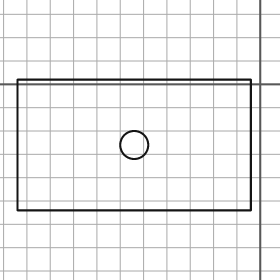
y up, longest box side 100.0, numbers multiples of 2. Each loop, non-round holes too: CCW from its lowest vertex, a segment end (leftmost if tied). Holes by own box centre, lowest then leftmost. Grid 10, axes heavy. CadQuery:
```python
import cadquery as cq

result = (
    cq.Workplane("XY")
    .moveTo(-104.0, -54.0)
    .lineTo(-4.0, -54.0)
    .lineTo(-4.0, 2.0)
    .lineTo(-104.0, 2.0)
    .close()
    .moveTo(-54.0, -26.0)
    .circle(6.0)
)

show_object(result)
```